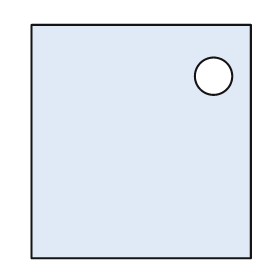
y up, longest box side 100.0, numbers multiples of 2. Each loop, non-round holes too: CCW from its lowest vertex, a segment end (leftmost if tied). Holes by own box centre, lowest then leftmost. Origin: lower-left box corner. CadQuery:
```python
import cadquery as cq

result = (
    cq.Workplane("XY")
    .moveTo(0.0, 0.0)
    .lineTo(94.0, 0.0)
    .lineTo(94.0, 100.0)
    .lineTo(0.0, 100.0)
    .close()
    .moveTo(78.0, 78.0)
    .circle(8.0)
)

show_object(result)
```